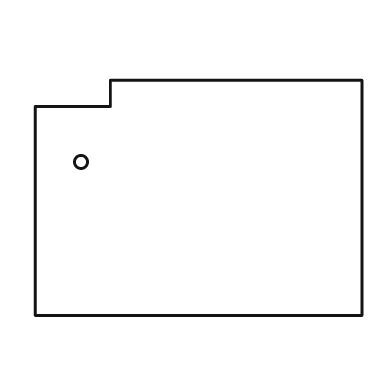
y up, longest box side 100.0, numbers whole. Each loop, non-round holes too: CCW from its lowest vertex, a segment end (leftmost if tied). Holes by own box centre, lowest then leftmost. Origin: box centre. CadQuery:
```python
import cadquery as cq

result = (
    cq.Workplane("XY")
    .moveTo(-50.0, -36.0)
    .lineTo(50.0, -36.0)
    .lineTo(50.0, 36.0)
    .lineTo(-27.0, 36.0)
    .lineTo(-27.0, 28.0)
    .lineTo(-50.0, 28.0)
    .close()
    .moveTo(-36.0, 11.0)
    .circle(2.0)
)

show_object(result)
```